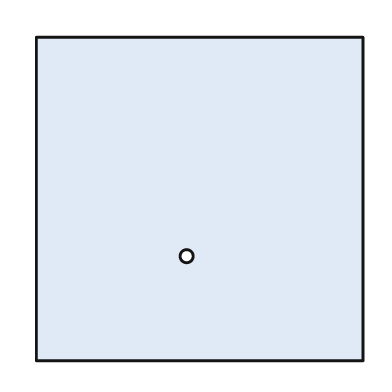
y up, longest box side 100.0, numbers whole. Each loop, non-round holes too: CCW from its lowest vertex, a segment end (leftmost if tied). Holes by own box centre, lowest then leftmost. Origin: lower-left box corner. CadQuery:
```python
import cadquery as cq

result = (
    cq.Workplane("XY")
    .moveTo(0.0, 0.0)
    .lineTo(100.0, 0.0)
    .lineTo(100.0, 99.0)
    .lineTo(0.0, 99.0)
    .close()
    .moveTo(46.0, 32.0)
    .circle(2.0)
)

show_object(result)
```